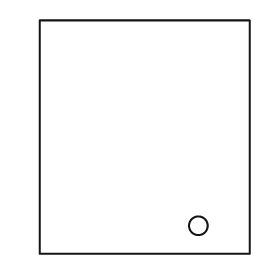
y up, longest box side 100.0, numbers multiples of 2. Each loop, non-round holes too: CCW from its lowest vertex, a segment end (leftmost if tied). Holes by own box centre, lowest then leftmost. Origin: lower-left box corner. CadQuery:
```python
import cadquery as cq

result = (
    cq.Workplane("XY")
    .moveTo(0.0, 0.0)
    .lineTo(90.0, 0.0)
    .lineTo(90.0, 100.0)
    .lineTo(0.0, 100.0)
    .close()
    .moveTo(68.0, 12.0)
    .circle(4.0)
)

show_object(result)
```